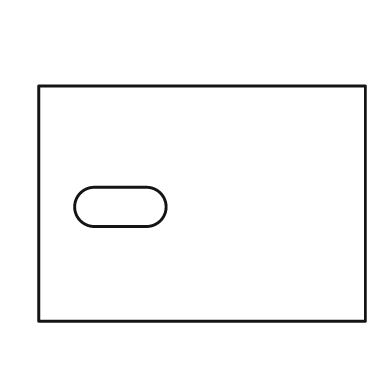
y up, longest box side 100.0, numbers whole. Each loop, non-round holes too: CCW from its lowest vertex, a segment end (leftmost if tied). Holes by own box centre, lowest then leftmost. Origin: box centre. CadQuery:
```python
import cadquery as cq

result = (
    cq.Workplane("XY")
    .moveTo(-50.0, -36.0)
    .lineTo(50.0, -36.0)
    .lineTo(50.0, 36.0)
    .lineTo(-50.0, 36.0)
    .close()
    .moveTo(-33.0, -7.0)
    .lineTo(-17.0, -7.0)
    .threePointArc((-11.0, -1.0), (-17.0, 5.0))
    .lineTo(-33.0, 5.0)
    .threePointArc((-39.0, -1.0), (-33.0, -7.0))
    .close()
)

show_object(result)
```